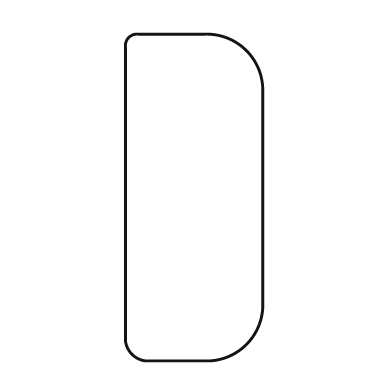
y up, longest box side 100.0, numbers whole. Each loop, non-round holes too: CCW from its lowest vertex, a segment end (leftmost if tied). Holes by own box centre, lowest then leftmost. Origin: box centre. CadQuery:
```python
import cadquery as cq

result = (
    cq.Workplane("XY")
    .moveTo(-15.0, -50.0)
    .lineTo(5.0, -50.0)
    .threePointArc((16.0, -45.0), (21.0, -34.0))
    .lineTo(21.0, 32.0)
    .threePointArc((16.0, 45.0), (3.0, 50.0))
    .lineTo(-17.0, 50.0)
    .threePointArc((-20.0, 49.0), (-21.0, 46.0))
    .lineTo(-21.0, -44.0)
    .threePointArc((-19.0, -48.0), (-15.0, -50.0))
    .close()
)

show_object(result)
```